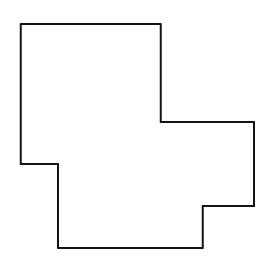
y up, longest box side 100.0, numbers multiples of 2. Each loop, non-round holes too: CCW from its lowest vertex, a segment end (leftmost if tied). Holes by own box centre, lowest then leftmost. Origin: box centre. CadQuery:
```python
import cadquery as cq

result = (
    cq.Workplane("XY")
    .moveTo(-34.0, -48.0)
    .lineTo(28.0, -48.0)
    .lineTo(28.0, -30.0)
    .lineTo(50.0, -30.0)
    .lineTo(50.0, 6.0)
    .lineTo(10.0, 6.0)
    .lineTo(10.0, 48.0)
    .lineTo(-50.0, 48.0)
    .lineTo(-50.0, -12.0)
    .lineTo(-34.0, -12.0)
    .close()
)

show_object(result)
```